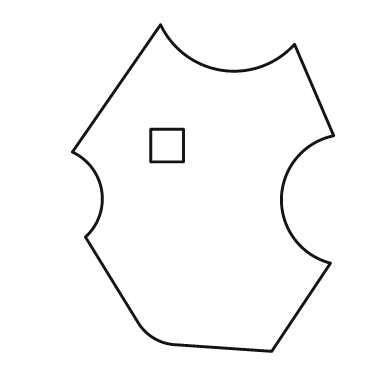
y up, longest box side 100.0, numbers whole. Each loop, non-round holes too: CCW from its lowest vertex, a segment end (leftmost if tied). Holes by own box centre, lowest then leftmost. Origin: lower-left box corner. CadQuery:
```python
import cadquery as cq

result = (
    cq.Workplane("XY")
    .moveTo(61.0, 0.0)
    .lineTo(79.0, 27.0)
    .threePointArc((64.0, 47.0), (80.0, 66.0))
    .lineTo(68.0, 94.0)
    .threePointArc((46.0, 86.0), (27.0, 100.0))
    .lineTo(0.0, 61.0)
    .threePointArc((9.0, 49.0), (4.0, 35.0))
    .lineTo(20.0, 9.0)
    .threePointArc((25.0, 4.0), (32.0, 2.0))
    .close()
    .moveTo(24.0, 58.0)
    .lineTo(34.0, 58.0)
    .lineTo(34.0, 68.0)
    .lineTo(24.0, 68.0)
    .close()
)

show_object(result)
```